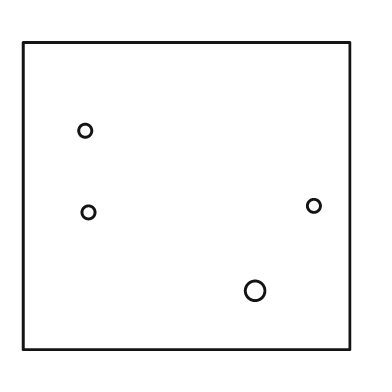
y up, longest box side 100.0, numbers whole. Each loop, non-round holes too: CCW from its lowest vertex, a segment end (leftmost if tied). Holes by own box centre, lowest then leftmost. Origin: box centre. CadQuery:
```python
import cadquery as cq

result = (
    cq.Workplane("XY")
    .moveTo(-50.0, -47.0)
    .lineTo(50.0, -47.0)
    .lineTo(50.0, 47.0)
    .lineTo(-50.0, 47.0)
    .close()
    .moveTo(21.0, -29.0)
    .circle(3.0)
    .moveTo(-30.0, -5.0)
    .circle(2.0)
    .moveTo(39.0, -3.0)
    .circle(2.0)
    .moveTo(-31.0, 20.0)
    .circle(2.0)
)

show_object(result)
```